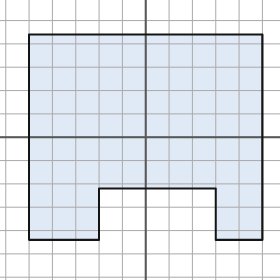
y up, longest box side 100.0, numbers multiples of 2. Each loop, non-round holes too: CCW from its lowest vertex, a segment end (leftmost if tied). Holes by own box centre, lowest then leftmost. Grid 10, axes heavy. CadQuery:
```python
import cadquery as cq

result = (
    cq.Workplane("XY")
    .moveTo(-50.0, -44.0)
    .lineTo(-20.0, -44.0)
    .lineTo(-20.0, -22.0)
    .lineTo(30.0, -22.0)
    .lineTo(30.0, -44.0)
    .lineTo(50.0, -44.0)
    .lineTo(50.0, 44.0)
    .lineTo(-50.0, 44.0)
    .close()
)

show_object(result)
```